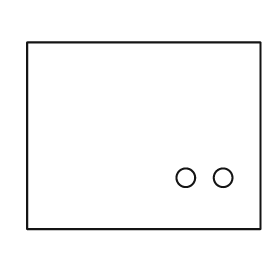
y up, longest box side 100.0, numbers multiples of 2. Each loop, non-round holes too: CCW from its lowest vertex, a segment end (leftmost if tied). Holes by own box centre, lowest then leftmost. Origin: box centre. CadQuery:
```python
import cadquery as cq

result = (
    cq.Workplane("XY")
    .moveTo(-50.0, -40.0)
    .lineTo(50.0, -40.0)
    .lineTo(50.0, 40.0)
    .lineTo(-50.0, 40.0)
    .close()
    .moveTo(18.0, -18.0)
    .circle(4.0)
    .moveTo(34.0, -18.0)
    .circle(4.0)
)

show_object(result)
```